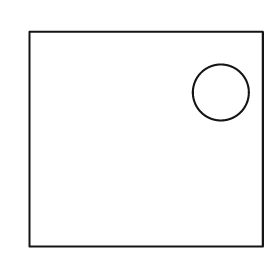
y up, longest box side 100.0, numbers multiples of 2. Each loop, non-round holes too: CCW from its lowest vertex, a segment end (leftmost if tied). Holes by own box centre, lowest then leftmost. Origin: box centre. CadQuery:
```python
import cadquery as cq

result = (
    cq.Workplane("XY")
    .moveTo(-50.0, -46.0)
    .lineTo(50.0, -46.0)
    .lineTo(50.0, 46.0)
    .lineTo(-50.0, 46.0)
    .close()
    .moveTo(32.0, 20.0)
    .circle(12.0)
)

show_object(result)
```